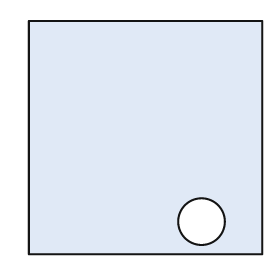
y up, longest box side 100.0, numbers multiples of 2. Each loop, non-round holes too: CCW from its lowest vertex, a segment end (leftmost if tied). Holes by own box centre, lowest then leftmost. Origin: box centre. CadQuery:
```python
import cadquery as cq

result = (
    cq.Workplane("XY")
    .moveTo(-50.0, -50.0)
    .lineTo(50.0, -50.0)
    .lineTo(50.0, 50.0)
    .lineTo(-50.0, 50.0)
    .close()
    .moveTo(24.0, -36.0)
    .circle(10.0)
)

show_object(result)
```